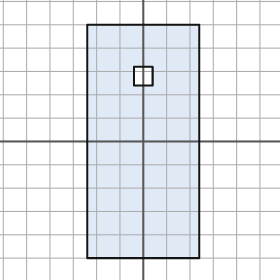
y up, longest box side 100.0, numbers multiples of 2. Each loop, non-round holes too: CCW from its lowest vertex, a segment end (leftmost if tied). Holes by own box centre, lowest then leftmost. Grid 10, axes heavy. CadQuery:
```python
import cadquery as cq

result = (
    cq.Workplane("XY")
    .moveTo(-24.0, -50.0)
    .lineTo(24.0, -50.0)
    .lineTo(24.0, 50.0)
    .lineTo(-24.0, 50.0)
    .close()
    .moveTo(-4.0, 24.0)
    .lineTo(4.0, 24.0)
    .lineTo(4.0, 32.0)
    .lineTo(-4.0, 32.0)
    .close()
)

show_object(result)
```